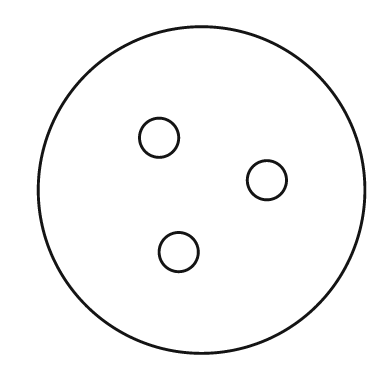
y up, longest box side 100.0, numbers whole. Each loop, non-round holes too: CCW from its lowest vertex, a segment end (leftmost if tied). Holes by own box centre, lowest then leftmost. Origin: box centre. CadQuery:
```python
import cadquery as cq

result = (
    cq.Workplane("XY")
    .moveTo(0.0, 0.0)
    .circle(50.0)
    .moveTo(-7.0, -19.0)
    .circle(6.0)
    .moveTo(20.0, 3.0)
    .circle(6.0)
    .moveTo(-13.0, 16.0)
    .circle(6.0)
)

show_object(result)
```